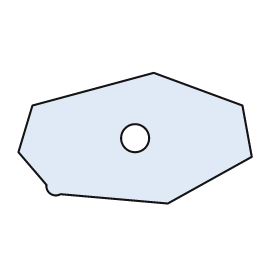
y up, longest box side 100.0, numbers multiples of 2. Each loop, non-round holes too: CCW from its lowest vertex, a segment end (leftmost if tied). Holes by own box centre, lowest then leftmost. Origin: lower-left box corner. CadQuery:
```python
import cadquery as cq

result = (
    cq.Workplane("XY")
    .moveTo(64.0, 0.0)
    .lineTo(100.0, 20.0)
    .lineTo(96.0, 42.0)
    .lineTo(58.0, 56.0)
    .lineTo(6.0, 42.0)
    .lineTo(0.0, 22.0)
    .lineTo(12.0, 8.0)
    .threePointArc((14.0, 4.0), (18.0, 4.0))
    .close()
    .moveTo(50.0, 28.0)
    .circle(6.0)
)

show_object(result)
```